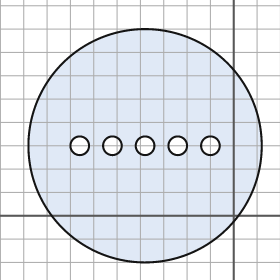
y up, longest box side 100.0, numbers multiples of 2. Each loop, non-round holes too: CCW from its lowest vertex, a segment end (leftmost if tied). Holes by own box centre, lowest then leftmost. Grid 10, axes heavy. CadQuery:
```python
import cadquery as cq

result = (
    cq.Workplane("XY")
    .moveTo(-38.0, 30.0)
    .circle(50.0)
    .moveTo(-66.0, 30.0)
    .circle(4.0)
    .moveTo(-52.0, 30.0)
    .circle(4.0)
    .moveTo(-38.0, 30.0)
    .circle(4.0)
    .moveTo(-24.0, 30.0)
    .circle(4.0)
    .moveTo(-10.0, 30.0)
    .circle(4.0)
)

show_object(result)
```